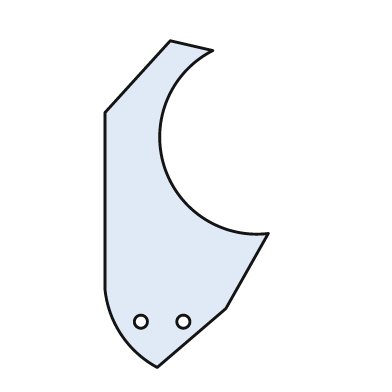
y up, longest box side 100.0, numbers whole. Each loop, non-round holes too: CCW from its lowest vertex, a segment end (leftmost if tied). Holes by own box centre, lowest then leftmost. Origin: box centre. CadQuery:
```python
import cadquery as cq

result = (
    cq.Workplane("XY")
    .moveTo(-9.0, -50.0)
    .lineTo(12.0, -32.0)
    .lineTo(25.0, -9.0)
    .threePointArc((-7.0, 12.0), (8.0, 47.0))
    .lineTo(-5.0, 50.0)
    .lineTo(-25.0, 28.0)
    .lineTo(-25.0, -26.0)
    .threePointArc((-20.0, -40.0), (-9.0, -50.0))
    .close()
    .moveTo(-14.0, -36.0)
    .circle(2.0)
    .moveTo(-1.0, -36.0)
    .circle(2.0)
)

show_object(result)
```